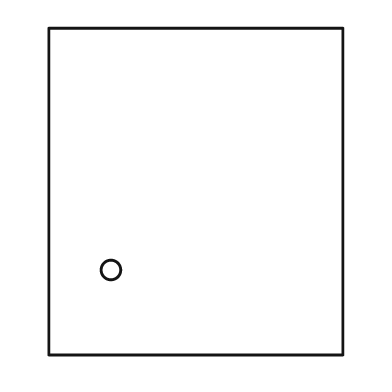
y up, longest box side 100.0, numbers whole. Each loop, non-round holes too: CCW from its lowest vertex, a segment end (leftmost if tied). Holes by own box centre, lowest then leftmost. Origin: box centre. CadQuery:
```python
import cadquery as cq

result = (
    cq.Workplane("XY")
    .moveTo(-45.0, -50.0)
    .lineTo(45.0, -50.0)
    .lineTo(45.0, 50.0)
    .lineTo(-45.0, 50.0)
    .close()
    .moveTo(-26.0, -24.0)
    .circle(3.0)
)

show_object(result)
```